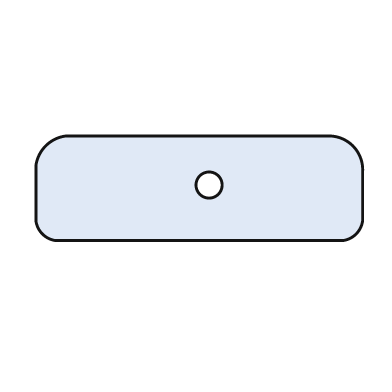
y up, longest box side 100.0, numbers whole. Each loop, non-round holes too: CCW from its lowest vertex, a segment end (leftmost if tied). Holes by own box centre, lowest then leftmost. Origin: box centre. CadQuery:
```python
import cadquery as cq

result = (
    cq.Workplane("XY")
    .moveTo(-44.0, -16.0)
    .lineTo(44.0, -16.0)
    .threePointArc((48.0, -14.0), (50.0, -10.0))
    .lineTo(50.0, 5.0)
    .threePointArc((47.0, 13.0), (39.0, 16.0))
    .lineTo(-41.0, 16.0)
    .threePointArc((-47.0, 13.0), (-50.0, 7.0))
    .lineTo(-50.0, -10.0)
    .threePointArc((-48.0, -14.0), (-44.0, -16.0))
    .close()
    .moveTo(3.0, 1.0)
    .circle(4.0)
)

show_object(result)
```